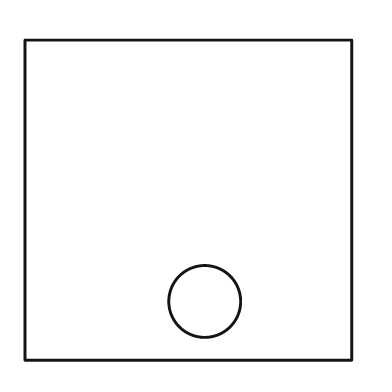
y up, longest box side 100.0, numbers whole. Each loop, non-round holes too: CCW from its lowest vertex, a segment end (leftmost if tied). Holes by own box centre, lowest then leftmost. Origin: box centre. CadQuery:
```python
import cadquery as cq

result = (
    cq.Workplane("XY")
    .moveTo(-50.0, -49.0)
    .lineTo(50.0, -49.0)
    .lineTo(50.0, 49.0)
    .lineTo(-50.0, 49.0)
    .close()
    .moveTo(5.0, -31.0)
    .circle(11.0)
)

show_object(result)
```